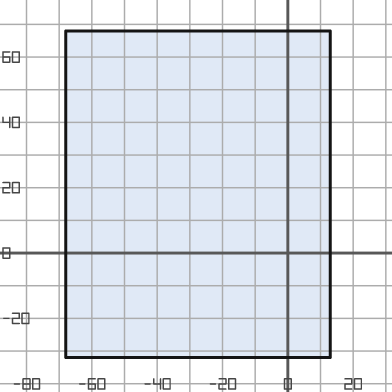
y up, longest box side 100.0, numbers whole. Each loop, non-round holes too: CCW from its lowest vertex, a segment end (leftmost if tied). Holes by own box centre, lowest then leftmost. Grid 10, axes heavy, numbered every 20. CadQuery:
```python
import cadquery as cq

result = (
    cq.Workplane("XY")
    .moveTo(-68.0, -32.0)
    .lineTo(13.0, -32.0)
    .lineTo(13.0, 68.0)
    .lineTo(-68.0, 68.0)
    .close()
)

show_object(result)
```